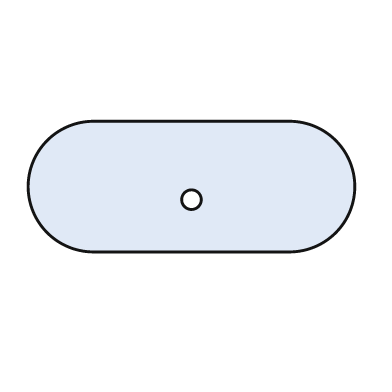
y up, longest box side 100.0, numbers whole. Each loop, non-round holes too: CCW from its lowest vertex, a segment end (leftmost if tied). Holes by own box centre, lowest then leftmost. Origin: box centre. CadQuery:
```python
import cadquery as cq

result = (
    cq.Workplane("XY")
    .moveTo(-30.0, -20.0)
    .lineTo(30.0, -20.0)
    .threePointArc((50.0, 0.0), (30.0, 20.0))
    .lineTo(-30.0, 20.0)
    .threePointArc((-50.0, 0.0), (-30.0, -20.0))
    .close()
    .moveTo(0.0, -4.0)
    .circle(3.0)
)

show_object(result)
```